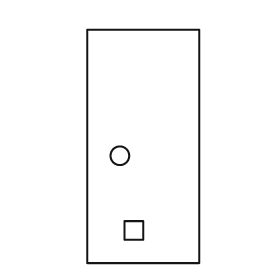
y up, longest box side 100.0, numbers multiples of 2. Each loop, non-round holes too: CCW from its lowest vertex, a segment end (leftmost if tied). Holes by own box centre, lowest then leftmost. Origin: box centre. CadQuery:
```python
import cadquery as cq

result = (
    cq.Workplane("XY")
    .moveTo(-24.0, -50.0)
    .lineTo(24.0, -50.0)
    .lineTo(24.0, 50.0)
    .lineTo(-24.0, 50.0)
    .close()
    .moveTo(-8.0, -40.0)
    .lineTo(0.0, -40.0)
    .lineTo(0.0, -32.0)
    .lineTo(-8.0, -32.0)
    .close()
    .moveTo(-10.0, -4.0)
    .circle(4.0)
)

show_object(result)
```